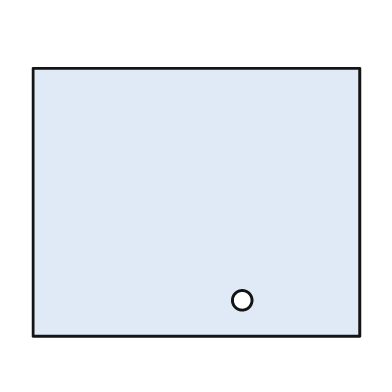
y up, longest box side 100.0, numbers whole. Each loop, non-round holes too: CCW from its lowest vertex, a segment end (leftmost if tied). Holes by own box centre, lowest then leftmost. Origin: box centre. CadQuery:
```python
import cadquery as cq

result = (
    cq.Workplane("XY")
    .moveTo(-50.0, -41.0)
    .lineTo(50.0, -41.0)
    .lineTo(50.0, 41.0)
    .lineTo(-50.0, 41.0)
    .close()
    .moveTo(14.0, -30.0)
    .circle(3.0)
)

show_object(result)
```